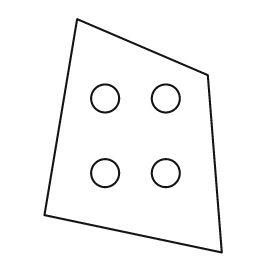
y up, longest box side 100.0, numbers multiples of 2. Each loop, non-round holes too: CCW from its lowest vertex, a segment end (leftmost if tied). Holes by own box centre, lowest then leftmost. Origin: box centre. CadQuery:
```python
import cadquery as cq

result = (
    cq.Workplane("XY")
    .moveTo(38.0, -50.0)
    .lineTo(32.0, 26.0)
    .lineTo(-24.0, 50.0)
    .lineTo(-38.0, -34.0)
    .close()
    .moveTo(-12.0, -16.0)
    .circle(6.0)
    .moveTo(14.0, -16.0)
    .circle(6.0)
    .moveTo(-12.0, 16.0)
    .circle(6.0)
    .moveTo(14.0, 16.0)
    .circle(6.0)
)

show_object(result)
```